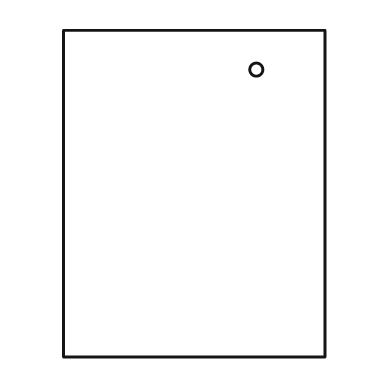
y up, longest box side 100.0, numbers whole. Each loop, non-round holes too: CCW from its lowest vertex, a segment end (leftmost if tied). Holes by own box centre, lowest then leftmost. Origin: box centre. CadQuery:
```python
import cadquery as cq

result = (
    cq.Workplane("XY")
    .moveTo(-40.0, -50.0)
    .lineTo(40.0, -50.0)
    .lineTo(40.0, 50.0)
    .lineTo(-40.0, 50.0)
    .close()
    .moveTo(19.0, 38.0)
    .circle(2.0)
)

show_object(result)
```